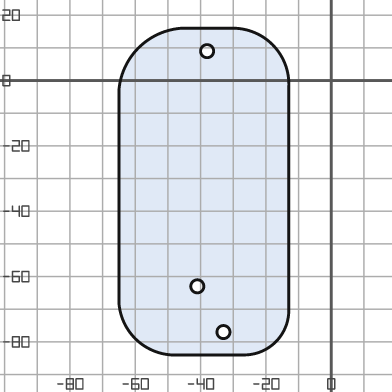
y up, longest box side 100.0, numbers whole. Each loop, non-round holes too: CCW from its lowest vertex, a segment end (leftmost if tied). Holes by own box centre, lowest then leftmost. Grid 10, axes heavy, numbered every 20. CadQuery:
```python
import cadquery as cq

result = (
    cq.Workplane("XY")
    .moveTo(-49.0, -84.0)
    .lineTo(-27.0, -84.0)
    .threePointArc((-17.0, -80.0), (-13.0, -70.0))
    .lineTo(-13.0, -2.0)
    .threePointArc((-18.0, 11.0), (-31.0, 16.0))
    .lineTo(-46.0, 16.0)
    .threePointArc((-59.0, 10.0), (-65.0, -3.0))
    .lineTo(-65.0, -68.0)
    .threePointArc((-60.0, -79.0), (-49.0, -84.0))
    .close()
    .moveTo(-33.0, -77.0)
    .circle(2.0)
    .moveTo(-41.0, -63.0)
    .circle(2.0)
    .moveTo(-38.0, 9.0)
    .circle(2.0)
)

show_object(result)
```